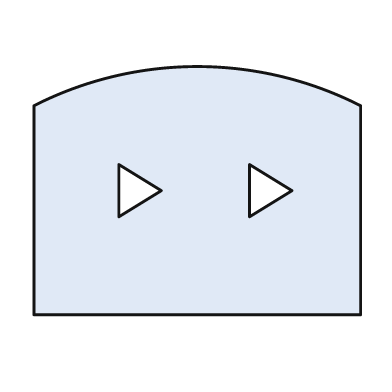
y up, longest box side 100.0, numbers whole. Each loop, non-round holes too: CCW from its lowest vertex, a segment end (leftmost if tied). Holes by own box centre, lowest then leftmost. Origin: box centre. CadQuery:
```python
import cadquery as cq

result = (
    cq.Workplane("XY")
    .moveTo(-50.0, -38.0)
    .lineTo(50.0, -38.0)
    .lineTo(50.0, 26.0)
    .threePointArc((0.0, 38.0), (-50.0, 26.0))
    .close()
    .moveTo(-24.0, -8.0)
    .lineTo(-11.0, 0.0)
    .lineTo(-24.0, 8.0)
    .close()
    .moveTo(16.0, -8.0)
    .lineTo(29.0, 0.0)
    .lineTo(16.0, 8.0)
    .close()
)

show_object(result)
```